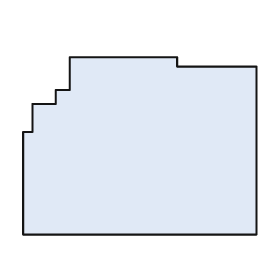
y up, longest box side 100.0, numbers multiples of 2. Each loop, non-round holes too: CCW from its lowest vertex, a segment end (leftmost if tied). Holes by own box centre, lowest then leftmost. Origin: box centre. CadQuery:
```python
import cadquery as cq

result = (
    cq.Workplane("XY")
    .moveTo(-50.0, -38.0)
    .lineTo(50.0, -38.0)
    .lineTo(50.0, 34.0)
    .lineTo(16.0, 34.0)
    .lineTo(16.0, 38.0)
    .lineTo(-30.0, 38.0)
    .lineTo(-30.0, 24.0)
    .lineTo(-36.0, 24.0)
    .lineTo(-36.0, 18.0)
    .lineTo(-46.0, 18.0)
    .lineTo(-46.0, 6.0)
    .lineTo(-50.0, 6.0)
    .close()
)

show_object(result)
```